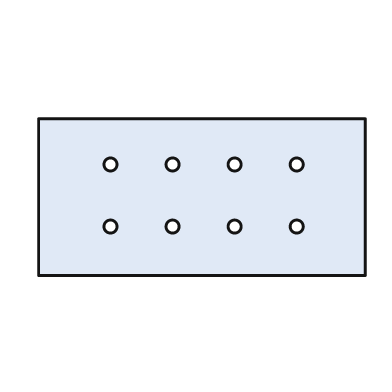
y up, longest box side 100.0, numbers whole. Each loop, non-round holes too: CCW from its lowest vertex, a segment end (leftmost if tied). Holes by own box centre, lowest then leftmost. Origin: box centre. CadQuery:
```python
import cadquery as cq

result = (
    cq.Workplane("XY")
    .moveTo(-50.0, -24.0)
    .lineTo(50.0, -24.0)
    .lineTo(50.0, 24.0)
    .lineTo(-50.0, 24.0)
    .close()
    .moveTo(-28.0, -9.0)
    .circle(2.0)
    .moveTo(-9.0, -9.0)
    .circle(2.0)
    .moveTo(10.0, -9.0)
    .circle(2.0)
    .moveTo(29.0, -9.0)
    .circle(2.0)
    .moveTo(-28.0, 10.0)
    .circle(2.0)
    .moveTo(-9.0, 10.0)
    .circle(2.0)
    .moveTo(10.0, 10.0)
    .circle(2.0)
    .moveTo(29.0, 10.0)
    .circle(2.0)
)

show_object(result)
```